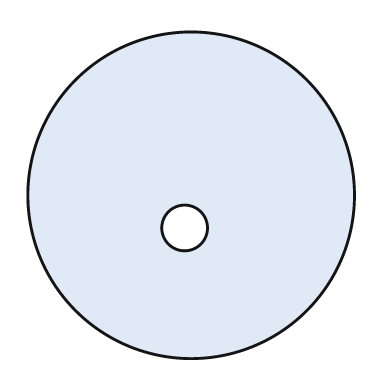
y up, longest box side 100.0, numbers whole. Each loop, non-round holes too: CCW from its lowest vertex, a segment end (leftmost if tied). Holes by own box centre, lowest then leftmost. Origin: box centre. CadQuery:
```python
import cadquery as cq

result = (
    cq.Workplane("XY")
    .moveTo(0.0, 0.0)
    .circle(50.0)
    .moveTo(-2.0, -10.0)
    .circle(7.0)
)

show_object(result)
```